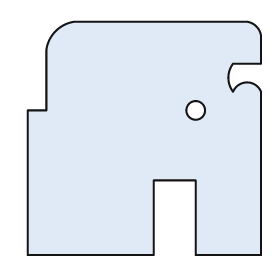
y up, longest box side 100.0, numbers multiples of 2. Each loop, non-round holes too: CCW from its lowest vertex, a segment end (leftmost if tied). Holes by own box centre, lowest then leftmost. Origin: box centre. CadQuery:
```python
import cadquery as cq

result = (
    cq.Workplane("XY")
    .moveTo(-50.0, -50.0)
    .lineTo(4.0, -50.0)
    .lineTo(4.0, -18.0)
    .lineTo(22.0, -18.0)
    .lineTo(22.0, -50.0)
    .lineTo(50.0, -50.0)
    .lineTo(50.0, 20.0)
    .threePointArc((44.0, 24.0), (38.0, 20.0))
    .threePointArc((36.0, 26.0), (38.0, 32.0))
    .lineTo(50.0, 32.0)
    .lineTo(50.0, 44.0)
    .threePointArc((48.0, 48.0), (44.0, 50.0))
    .lineTo(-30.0, 50.0)
    .threePointArc((-38.0, 46.0), (-42.0, 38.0))
    .lineTo(-42.0, 12.0)
    .lineTo(-50.0, 12.0)
    .close()
    .moveTo(22.0, 12.0)
    .circle(4.0)
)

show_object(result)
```